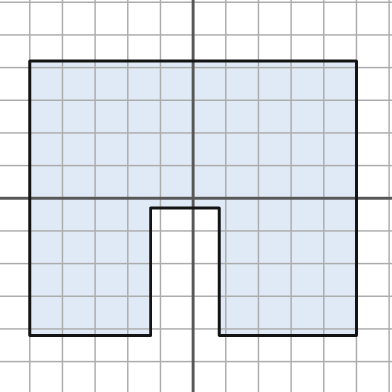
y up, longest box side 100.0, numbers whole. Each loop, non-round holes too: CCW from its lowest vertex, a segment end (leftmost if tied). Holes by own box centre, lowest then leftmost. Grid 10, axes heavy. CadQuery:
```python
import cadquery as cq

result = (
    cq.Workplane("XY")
    .moveTo(-50.0, -42.0)
    .lineTo(-13.0, -42.0)
    .lineTo(-13.0, -3.0)
    .lineTo(8.0, -3.0)
    .lineTo(8.0, -42.0)
    .lineTo(50.0, -42.0)
    .lineTo(50.0, 42.0)
    .lineTo(-50.0, 42.0)
    .close()
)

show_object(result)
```